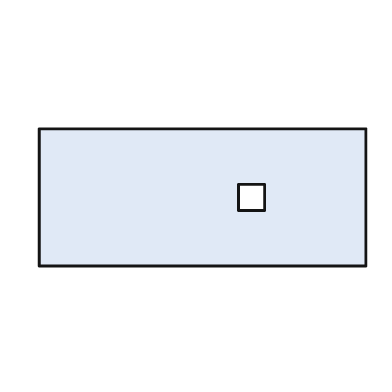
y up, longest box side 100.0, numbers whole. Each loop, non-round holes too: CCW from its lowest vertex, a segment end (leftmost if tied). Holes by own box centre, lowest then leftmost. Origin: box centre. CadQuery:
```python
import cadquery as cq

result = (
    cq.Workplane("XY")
    .moveTo(-50.0, -21.0)
    .lineTo(50.0, -21.0)
    .lineTo(50.0, 21.0)
    .lineTo(-50.0, 21.0)
    .close()
    .moveTo(11.0, -4.0)
    .lineTo(19.0, -4.0)
    .lineTo(19.0, 4.0)
    .lineTo(11.0, 4.0)
    .close()
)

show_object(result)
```